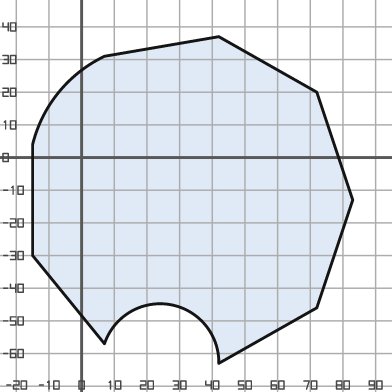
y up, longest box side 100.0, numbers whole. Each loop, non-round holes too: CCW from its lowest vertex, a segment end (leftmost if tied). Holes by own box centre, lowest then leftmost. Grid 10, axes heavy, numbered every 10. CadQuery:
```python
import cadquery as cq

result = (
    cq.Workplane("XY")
    .moveTo(42.0, -63.0)
    .lineTo(72.0, -46.0)
    .lineTo(83.0, -13.0)
    .lineTo(72.0, 20.0)
    .lineTo(42.0, 37.0)
    .lineTo(7.0, 31.0)
    .threePointArc((-7.0, 20.0), (-15.0, 4.0))
    .lineTo(-15.0, -30.0)
    .lineTo(7.0, -57.0)
    .threePointArc((27.0, -45.0), (42.0, -63.0))
    .close()
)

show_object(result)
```